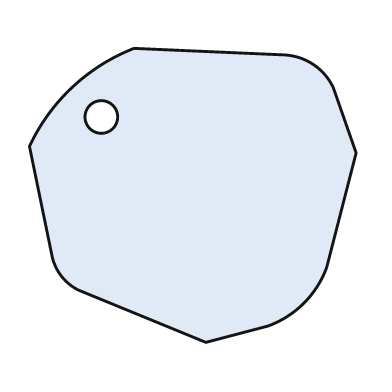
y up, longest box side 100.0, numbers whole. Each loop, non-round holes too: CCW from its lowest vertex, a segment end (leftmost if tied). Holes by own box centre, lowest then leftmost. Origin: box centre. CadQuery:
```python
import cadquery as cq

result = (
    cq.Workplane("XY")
    .moveTo(4.0, -45.0)
    .lineTo(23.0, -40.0)
    .threePointArc((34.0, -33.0), (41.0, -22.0))
    .lineTo(50.0, 13.0)
    .lineTo(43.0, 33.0)
    .threePointArc((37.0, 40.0), (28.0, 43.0))
    .lineTo(-18.0, 45.0)
    .threePointArc((-37.0, 33.0), (-50.0, 15.0))
    .lineTo(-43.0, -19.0)
    .threePointArc((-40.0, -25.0), (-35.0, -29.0))
    .close()
    .moveTo(-28.0, 24.0)
    .circle(5.0)
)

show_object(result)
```